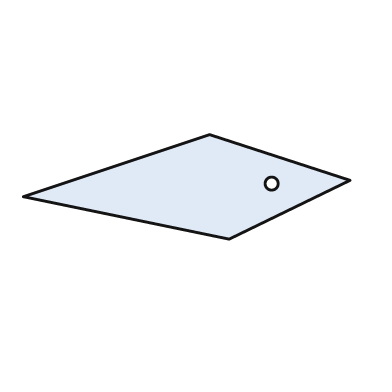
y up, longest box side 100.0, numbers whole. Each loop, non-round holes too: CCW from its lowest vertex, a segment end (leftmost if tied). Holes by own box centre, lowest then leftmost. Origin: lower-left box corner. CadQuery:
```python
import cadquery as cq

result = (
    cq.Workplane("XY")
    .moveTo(63.0, 0.0)
    .lineTo(100.0, 18.0)
    .lineTo(57.0, 32.0)
    .lineTo(0.0, 13.0)
    .close()
    .moveTo(76.0, 17.0)
    .circle(2.0)
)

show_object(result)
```